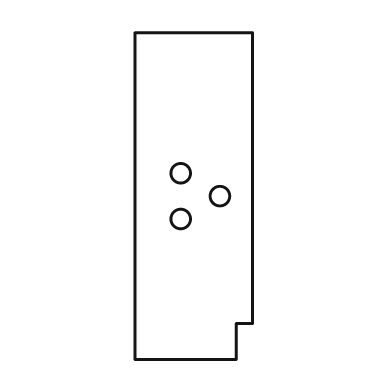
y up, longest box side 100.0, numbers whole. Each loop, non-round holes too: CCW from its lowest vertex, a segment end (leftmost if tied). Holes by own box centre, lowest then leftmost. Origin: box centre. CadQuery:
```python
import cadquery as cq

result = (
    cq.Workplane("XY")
    .moveTo(-18.0, -50.0)
    .lineTo(13.0, -50.0)
    .lineTo(13.0, -39.0)
    .lineTo(18.0, -39.0)
    .lineTo(18.0, 50.0)
    .lineTo(-18.0, 50.0)
    .close()
    .moveTo(-4.0, -7.0)
    .circle(3.0)
    .moveTo(8.0, 0.0)
    .circle(3.0)
    .moveTo(-4.0, 7.0)
    .circle(3.0)
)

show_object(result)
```